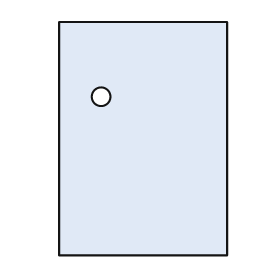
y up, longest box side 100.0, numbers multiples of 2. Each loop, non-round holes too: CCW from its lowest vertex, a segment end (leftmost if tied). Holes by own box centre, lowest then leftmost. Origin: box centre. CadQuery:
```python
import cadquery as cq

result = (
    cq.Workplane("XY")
    .moveTo(-36.0, -50.0)
    .lineTo(36.0, -50.0)
    .lineTo(36.0, 50.0)
    .lineTo(-36.0, 50.0)
    .close()
    .moveTo(-18.0, 18.0)
    .circle(4.0)
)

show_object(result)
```